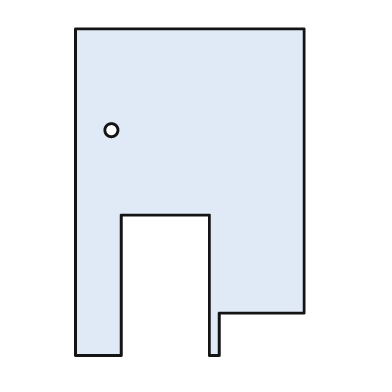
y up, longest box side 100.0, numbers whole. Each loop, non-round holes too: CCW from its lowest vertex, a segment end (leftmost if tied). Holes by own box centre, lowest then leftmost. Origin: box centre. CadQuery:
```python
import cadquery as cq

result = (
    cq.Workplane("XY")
    .moveTo(-35.0, -50.0)
    .lineTo(-21.0, -50.0)
    .lineTo(-21.0, -7.0)
    .lineTo(6.0, -7.0)
    .lineTo(6.0, -50.0)
    .lineTo(9.0, -50.0)
    .lineTo(9.0, -37.0)
    .lineTo(35.0, -37.0)
    .lineTo(35.0, 50.0)
    .lineTo(-35.0, 50.0)
    .close()
    .moveTo(-24.0, 19.0)
    .circle(2.0)
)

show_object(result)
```